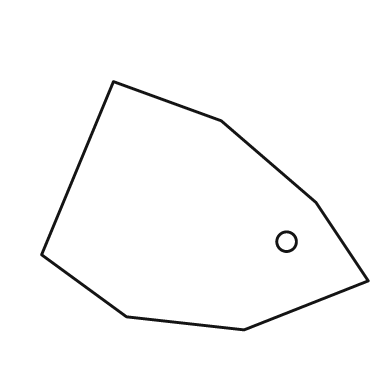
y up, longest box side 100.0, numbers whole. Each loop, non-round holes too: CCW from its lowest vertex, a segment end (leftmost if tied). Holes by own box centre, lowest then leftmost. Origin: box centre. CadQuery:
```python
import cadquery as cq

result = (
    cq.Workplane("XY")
    .moveTo(12.0, -38.0)
    .lineTo(50.0, -23.0)
    .lineTo(34.0, 1.0)
    .lineTo(5.0, 26.0)
    .lineTo(-28.0, 38.0)
    .lineTo(-50.0, -15.0)
    .lineTo(-24.0, -34.0)
    .close()
    .moveTo(25.0, -11.0)
    .circle(3.0)
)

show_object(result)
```